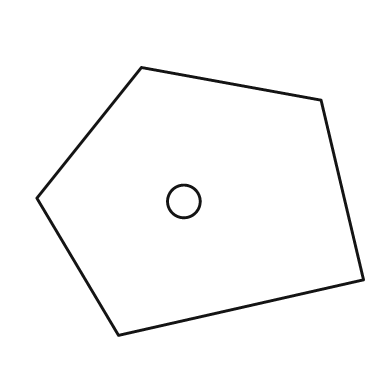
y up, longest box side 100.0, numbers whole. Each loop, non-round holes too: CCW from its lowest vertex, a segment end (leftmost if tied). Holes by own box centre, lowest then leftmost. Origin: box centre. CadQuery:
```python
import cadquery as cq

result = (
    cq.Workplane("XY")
    .moveTo(-25.0, -41.0)
    .lineTo(50.0, -24.0)
    .lineTo(37.0, 31.0)
    .lineTo(-18.0, 41.0)
    .lineTo(-50.0, 1.0)
    .close()
    .moveTo(-5.0, 0.0)
    .circle(5.0)
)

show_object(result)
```